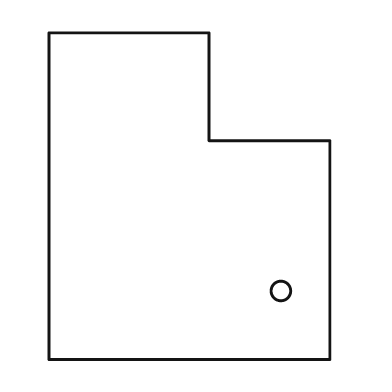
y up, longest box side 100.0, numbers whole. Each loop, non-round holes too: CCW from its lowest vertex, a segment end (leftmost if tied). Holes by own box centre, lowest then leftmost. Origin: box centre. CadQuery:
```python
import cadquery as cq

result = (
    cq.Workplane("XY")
    .moveTo(-43.0, -50.0)
    .lineTo(43.0, -50.0)
    .lineTo(43.0, 17.0)
    .lineTo(6.0, 17.0)
    .lineTo(6.0, 50.0)
    .lineTo(-43.0, 50.0)
    .close()
    .moveTo(28.0, -29.0)
    .circle(3.0)
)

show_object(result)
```